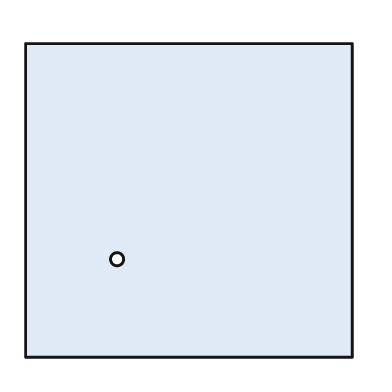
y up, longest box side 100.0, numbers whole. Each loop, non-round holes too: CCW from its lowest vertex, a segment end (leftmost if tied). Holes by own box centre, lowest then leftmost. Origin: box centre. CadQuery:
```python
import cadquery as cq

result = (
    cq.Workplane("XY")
    .moveTo(-50.0, -48.0)
    .lineTo(50.0, -48.0)
    .lineTo(50.0, 48.0)
    .lineTo(-50.0, 48.0)
    .close()
    .moveTo(-22.0, -18.0)
    .circle(2.0)
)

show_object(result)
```